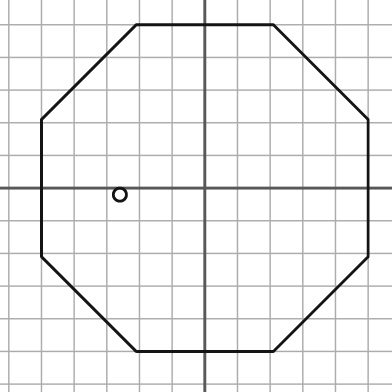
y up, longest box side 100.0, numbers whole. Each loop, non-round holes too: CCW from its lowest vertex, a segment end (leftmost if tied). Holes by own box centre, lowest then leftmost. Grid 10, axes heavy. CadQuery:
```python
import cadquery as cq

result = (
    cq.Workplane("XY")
    .moveTo(-21.0, -50.0)
    .lineTo(21.0, -50.0)
    .lineTo(50.0, -21.0)
    .lineTo(50.0, 21.0)
    .lineTo(21.0, 50.0)
    .lineTo(-21.0, 50.0)
    .lineTo(-50.0, 21.0)
    .lineTo(-50.0, -21.0)
    .close()
    .moveTo(-26.0, -2.0)
    .circle(2.0)
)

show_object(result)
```